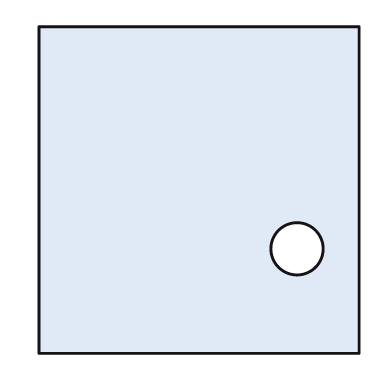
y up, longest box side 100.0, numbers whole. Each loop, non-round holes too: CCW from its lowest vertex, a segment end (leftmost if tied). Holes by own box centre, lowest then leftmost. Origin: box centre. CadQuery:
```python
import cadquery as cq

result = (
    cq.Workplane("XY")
    .moveTo(-49.0, -50.0)
    .lineTo(49.0, -50.0)
    .lineTo(49.0, 50.0)
    .lineTo(-49.0, 50.0)
    .close()
    .moveTo(30.0, -18.0)
    .circle(8.0)
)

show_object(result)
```